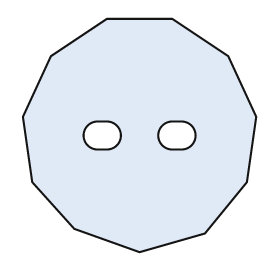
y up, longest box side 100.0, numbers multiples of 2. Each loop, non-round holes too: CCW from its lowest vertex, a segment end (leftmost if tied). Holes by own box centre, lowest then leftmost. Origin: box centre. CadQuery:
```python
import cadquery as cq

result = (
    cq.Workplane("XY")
    .moveTo(0.0, -50.0)
    .lineTo(28.0, -42.0)
    .lineTo(46.0, -20.0)
    .lineTo(50.0, 8.0)
    .lineTo(38.0, 34.0)
    .lineTo(14.0, 50.0)
    .lineTo(-14.0, 50.0)
    .lineTo(-38.0, 34.0)
    .lineTo(-50.0, 8.0)
    .lineTo(-46.0, -20.0)
    .lineTo(-28.0, -40.0)
    .close()
    .moveTo(-18.0, -6.0)
    .lineTo(-14.0, -6.0)
    .threePointArc((-8.0, 0.0), (-14.0, 6.0))
    .lineTo(-18.0, 6.0)
    .threePointArc((-24.0, 0.0), (-18.0, -6.0))
    .close()
    .moveTo(14.0, -6.0)
    .lineTo(18.0, -6.0)
    .threePointArc((24.0, 0.0), (18.0, 6.0))
    .lineTo(14.0, 6.0)
    .threePointArc((8.0, 0.0), (14.0, -6.0))
    .close()
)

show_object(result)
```